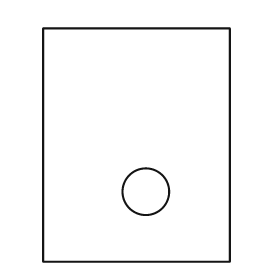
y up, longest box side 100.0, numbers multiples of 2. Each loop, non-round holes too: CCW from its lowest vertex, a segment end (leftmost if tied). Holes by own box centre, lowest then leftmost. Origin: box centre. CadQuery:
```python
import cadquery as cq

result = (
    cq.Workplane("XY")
    .moveTo(-40.0, -50.0)
    .lineTo(40.0, -50.0)
    .lineTo(40.0, 50.0)
    .lineTo(-40.0, 50.0)
    .close()
    .moveTo(4.0, -20.0)
    .circle(10.0)
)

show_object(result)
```